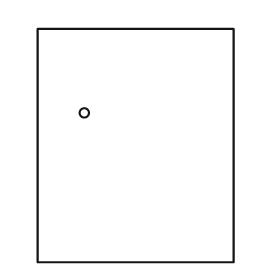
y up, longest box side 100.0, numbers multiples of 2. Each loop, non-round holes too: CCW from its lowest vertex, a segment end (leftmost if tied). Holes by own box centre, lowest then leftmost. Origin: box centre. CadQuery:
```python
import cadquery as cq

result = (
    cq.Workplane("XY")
    .moveTo(-42.0, -50.0)
    .lineTo(42.0, -50.0)
    .lineTo(42.0, 50.0)
    .lineTo(-42.0, 50.0)
    .close()
    .moveTo(-22.0, 14.0)
    .circle(2.0)
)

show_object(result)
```